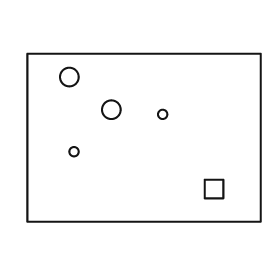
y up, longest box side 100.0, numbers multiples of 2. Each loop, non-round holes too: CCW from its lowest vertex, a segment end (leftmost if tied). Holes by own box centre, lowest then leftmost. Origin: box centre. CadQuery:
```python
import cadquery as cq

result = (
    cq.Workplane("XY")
    .moveTo(-50.0, -36.0)
    .lineTo(50.0, -36.0)
    .lineTo(50.0, 36.0)
    .lineTo(-50.0, 36.0)
    .close()
    .moveTo(26.0, -26.0)
    .lineTo(34.0, -26.0)
    .lineTo(34.0, -18.0)
    .lineTo(26.0, -18.0)
    .close()
    .moveTo(-30.0, -6.0)
    .circle(2.0)
    .moveTo(8.0, 10.0)
    .circle(2.0)
    .moveTo(-14.0, 12.0)
    .circle(4.0)
    .moveTo(-32.0, 26.0)
    .circle(4.0)
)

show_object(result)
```